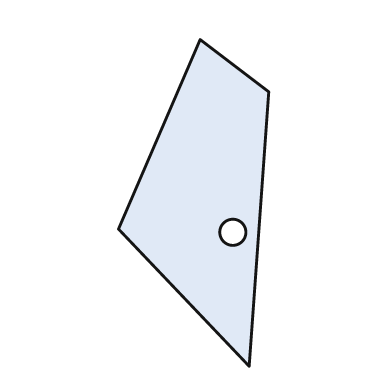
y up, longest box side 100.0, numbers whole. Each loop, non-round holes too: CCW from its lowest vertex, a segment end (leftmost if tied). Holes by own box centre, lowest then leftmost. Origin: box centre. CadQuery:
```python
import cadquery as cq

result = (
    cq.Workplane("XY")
    .moveTo(17.0, -50.0)
    .lineTo(23.0, 34.0)
    .lineTo(2.0, 50.0)
    .lineTo(-23.0, -8.0)
    .close()
    .moveTo(12.0, -9.0)
    .circle(4.0)
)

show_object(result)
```